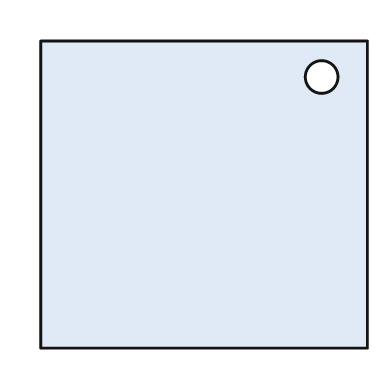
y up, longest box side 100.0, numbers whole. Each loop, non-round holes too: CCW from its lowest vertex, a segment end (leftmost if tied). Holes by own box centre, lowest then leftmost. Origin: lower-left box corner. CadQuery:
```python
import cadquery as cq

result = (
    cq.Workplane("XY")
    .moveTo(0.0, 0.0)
    .lineTo(100.0, 0.0)
    .lineTo(100.0, 94.0)
    .lineTo(0.0, 94.0)
    .close()
    .moveTo(86.0, 83.0)
    .circle(5.0)
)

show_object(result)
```